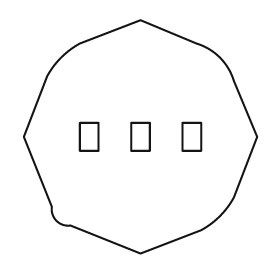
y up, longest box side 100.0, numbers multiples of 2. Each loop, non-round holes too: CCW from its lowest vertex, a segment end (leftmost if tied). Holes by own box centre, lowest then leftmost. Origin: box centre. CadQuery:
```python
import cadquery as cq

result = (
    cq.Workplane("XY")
    .moveTo(0.0, -50.0)
    .lineTo(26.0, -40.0)
    .threePointArc((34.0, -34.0), (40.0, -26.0))
    .lineTo(50.0, 0.0)
    .lineTo(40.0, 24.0)
    .threePointArc((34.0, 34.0), (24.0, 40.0))
    .lineTo(0.0, 50.0)
    .lineTo(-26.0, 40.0)
    .threePointArc((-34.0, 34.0), (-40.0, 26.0))
    .lineTo(-50.0, 0.0)
    .lineTo(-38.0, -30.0)
    .threePointArc((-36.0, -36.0), (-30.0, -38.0))
    .close()
    .moveTo(-26.0, -6.0)
    .lineTo(-18.0, -6.0)
    .lineTo(-18.0, 6.0)
    .lineTo(-26.0, 6.0)
    .close()
    .moveTo(-4.0, -6.0)
    .lineTo(4.0, -6.0)
    .lineTo(4.0, 6.0)
    .lineTo(-4.0, 6.0)
    .close()
    .moveTo(18.0, -6.0)
    .lineTo(26.0, -6.0)
    .lineTo(26.0, 6.0)
    .lineTo(18.0, 6.0)
    .close()
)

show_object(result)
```